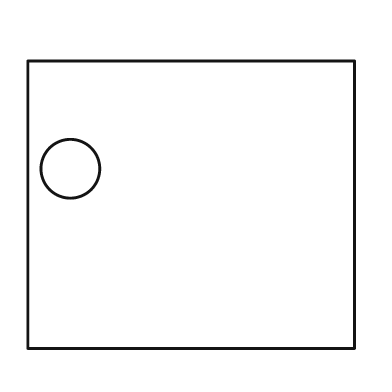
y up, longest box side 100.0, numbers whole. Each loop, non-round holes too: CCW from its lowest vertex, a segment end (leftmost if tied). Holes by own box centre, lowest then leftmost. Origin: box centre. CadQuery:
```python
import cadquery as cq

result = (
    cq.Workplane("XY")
    .moveTo(-50.0, -44.0)
    .lineTo(50.0, -44.0)
    .lineTo(50.0, 44.0)
    .lineTo(-50.0, 44.0)
    .close()
    .moveTo(-37.0, 11.0)
    .circle(9.0)
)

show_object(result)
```